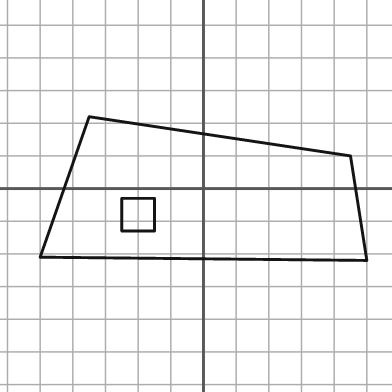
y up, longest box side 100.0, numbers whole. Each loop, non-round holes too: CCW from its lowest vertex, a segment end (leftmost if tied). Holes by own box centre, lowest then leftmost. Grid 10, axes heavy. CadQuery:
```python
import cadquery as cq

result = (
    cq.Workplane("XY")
    .moveTo(50.0, -22.0)
    .lineTo(45.0, 10.0)
    .lineTo(-35.0, 22.0)
    .lineTo(-50.0, -21.0)
    .close()
    .moveTo(-25.0, -13.0)
    .lineTo(-15.0, -13.0)
    .lineTo(-15.0, -3.0)
    .lineTo(-25.0, -3.0)
    .close()
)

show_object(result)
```